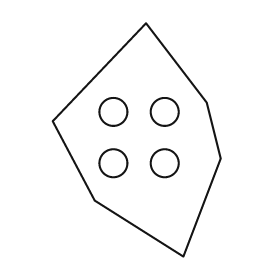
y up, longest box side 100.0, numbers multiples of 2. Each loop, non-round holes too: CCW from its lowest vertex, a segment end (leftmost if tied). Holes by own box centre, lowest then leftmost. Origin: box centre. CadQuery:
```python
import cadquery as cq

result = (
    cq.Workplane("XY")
    .moveTo(20.0, -50.0)
    .lineTo(36.0, -8.0)
    .lineTo(30.0, 16.0)
    .lineTo(4.0, 50.0)
    .lineTo(-36.0, 8.0)
    .lineTo(-18.0, -26.0)
    .close()
    .moveTo(-10.0, -10.0)
    .circle(6.0)
    .moveTo(12.0, -10.0)
    .circle(6.0)
    .moveTo(-10.0, 12.0)
    .circle(6.0)
    .moveTo(12.0, 12.0)
    .circle(6.0)
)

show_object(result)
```